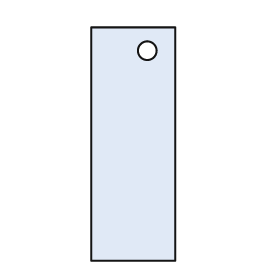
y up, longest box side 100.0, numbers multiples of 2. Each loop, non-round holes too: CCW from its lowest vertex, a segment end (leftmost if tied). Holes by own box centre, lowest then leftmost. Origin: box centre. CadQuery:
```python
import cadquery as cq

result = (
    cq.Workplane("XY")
    .moveTo(-18.0, -50.0)
    .lineTo(18.0, -50.0)
    .lineTo(18.0, 50.0)
    .lineTo(-18.0, 50.0)
    .close()
    .moveTo(6.0, 40.0)
    .circle(4.0)
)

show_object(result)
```